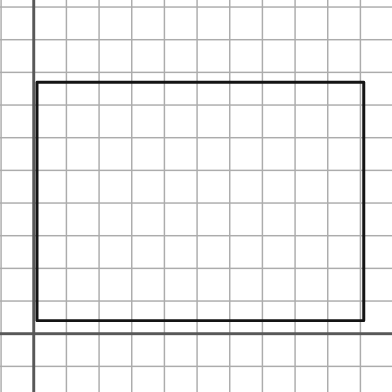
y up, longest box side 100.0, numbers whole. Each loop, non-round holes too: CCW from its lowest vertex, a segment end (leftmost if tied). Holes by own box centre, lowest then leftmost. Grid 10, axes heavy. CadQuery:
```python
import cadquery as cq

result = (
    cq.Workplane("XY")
    .moveTo(1.0, 4.0)
    .lineTo(101.0, 4.0)
    .lineTo(101.0, 77.0)
    .lineTo(1.0, 77.0)
    .close()
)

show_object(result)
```